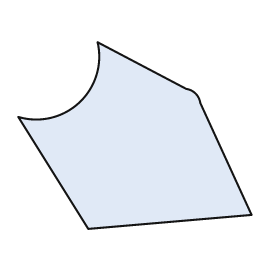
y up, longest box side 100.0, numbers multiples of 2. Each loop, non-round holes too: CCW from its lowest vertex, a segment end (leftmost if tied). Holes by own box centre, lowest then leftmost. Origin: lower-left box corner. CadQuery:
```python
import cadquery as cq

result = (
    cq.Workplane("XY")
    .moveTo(30.0, 0.0)
    .lineTo(100.0, 6.0)
    .lineTo(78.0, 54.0)
    .threePointArc((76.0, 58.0), (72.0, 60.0))
    .lineTo(34.0, 80.0)
    .threePointArc((26.0, 54.0), (0.0, 48.0))
    .close()
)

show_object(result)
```